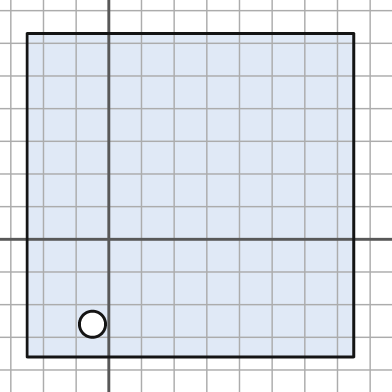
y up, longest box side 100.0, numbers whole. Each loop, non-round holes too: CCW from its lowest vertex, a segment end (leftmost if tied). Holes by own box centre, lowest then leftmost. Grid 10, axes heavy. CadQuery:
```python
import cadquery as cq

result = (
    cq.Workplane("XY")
    .moveTo(-25.0, -36.0)
    .lineTo(75.0, -36.0)
    .lineTo(75.0, 63.0)
    .lineTo(-25.0, 63.0)
    .close()
    .moveTo(-5.0, -26.0)
    .circle(4.0)
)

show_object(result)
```